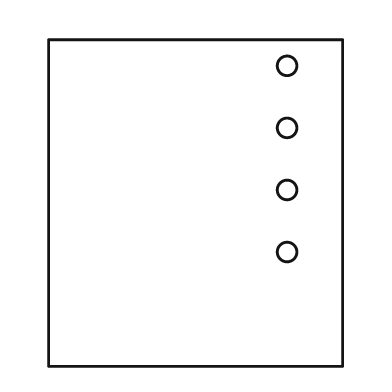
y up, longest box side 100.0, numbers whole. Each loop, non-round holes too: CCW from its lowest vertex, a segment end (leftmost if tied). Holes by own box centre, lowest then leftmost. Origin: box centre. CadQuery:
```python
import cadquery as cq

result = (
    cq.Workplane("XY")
    .moveTo(-45.0, -50.0)
    .lineTo(45.0, -50.0)
    .lineTo(45.0, 50.0)
    .lineTo(-45.0, 50.0)
    .close()
    .moveTo(28.0, -15.0)
    .circle(3.0)
    .moveTo(28.0, 4.0)
    .circle(3.0)
    .moveTo(28.0, 23.0)
    .circle(3.0)
    .moveTo(28.0, 42.0)
    .circle(3.0)
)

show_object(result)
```